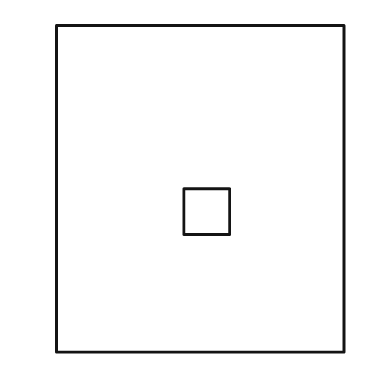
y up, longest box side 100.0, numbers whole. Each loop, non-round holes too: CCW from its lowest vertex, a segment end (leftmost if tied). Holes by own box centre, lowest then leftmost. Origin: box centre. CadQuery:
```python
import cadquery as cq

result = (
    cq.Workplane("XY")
    .moveTo(-44.0, -50.0)
    .lineTo(44.0, -50.0)
    .lineTo(44.0, 50.0)
    .lineTo(-44.0, 50.0)
    .close()
    .moveTo(-5.0, -14.0)
    .lineTo(9.0, -14.0)
    .lineTo(9.0, 0.0)
    .lineTo(-5.0, 0.0)
    .close()
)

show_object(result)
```